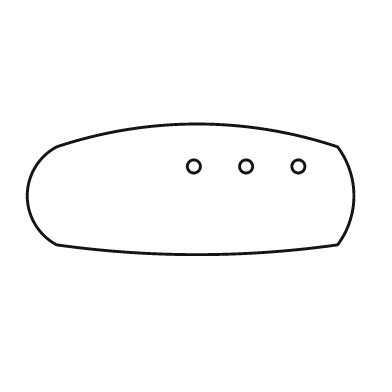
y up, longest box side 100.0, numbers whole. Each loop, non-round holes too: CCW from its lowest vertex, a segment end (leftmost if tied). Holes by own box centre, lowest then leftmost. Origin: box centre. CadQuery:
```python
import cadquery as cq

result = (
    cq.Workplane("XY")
    .moveTo(-41.0, -17.0)
    .threePointArc((2.0, -20.0), (45.0, -17.0))
    .threePointArc((50.0, -2.0), (45.0, 13.0))
    .threePointArc((2.0, 20.0), (-41.0, 13.0))
    .threePointArc((-50.0, -2.0), (-41.0, -17.0))
    .close()
    .moveTo(1.0, 7.0)
    .circle(2.0)
    .moveTo(17.0, 7.0)
    .circle(2.0)
    .moveTo(33.0, 7.0)
    .circle(2.0)
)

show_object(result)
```